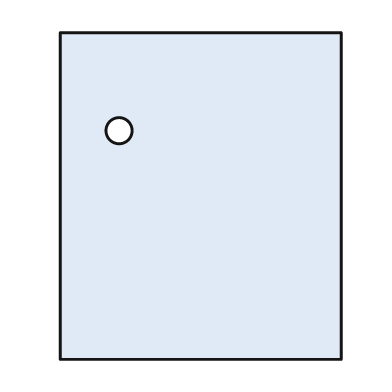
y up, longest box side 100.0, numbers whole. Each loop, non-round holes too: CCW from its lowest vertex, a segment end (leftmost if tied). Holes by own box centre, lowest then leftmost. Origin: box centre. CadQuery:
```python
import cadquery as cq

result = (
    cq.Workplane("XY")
    .moveTo(-43.0, -50.0)
    .lineTo(43.0, -50.0)
    .lineTo(43.0, 50.0)
    .lineTo(-43.0, 50.0)
    .close()
    .moveTo(-25.0, 20.0)
    .circle(4.0)
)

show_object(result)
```